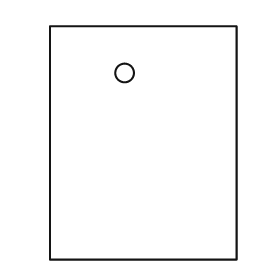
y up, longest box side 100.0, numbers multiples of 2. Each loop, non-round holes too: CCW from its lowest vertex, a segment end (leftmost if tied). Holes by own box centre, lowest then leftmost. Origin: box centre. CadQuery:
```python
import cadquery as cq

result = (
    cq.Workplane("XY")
    .moveTo(-40.0, -50.0)
    .lineTo(40.0, -50.0)
    .lineTo(40.0, 50.0)
    .lineTo(-40.0, 50.0)
    .close()
    .moveTo(-8.0, 30.0)
    .circle(4.0)
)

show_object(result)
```